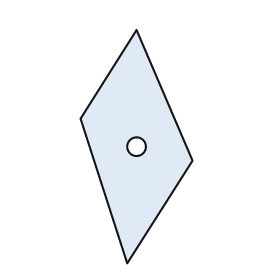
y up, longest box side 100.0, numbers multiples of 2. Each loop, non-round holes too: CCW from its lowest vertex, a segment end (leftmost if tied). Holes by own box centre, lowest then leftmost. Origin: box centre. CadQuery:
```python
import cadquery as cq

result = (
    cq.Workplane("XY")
    .moveTo(-4.0, -50.0)
    .lineTo(24.0, -6.0)
    .lineTo(0.0, 50.0)
    .lineTo(-24.0, 12.0)
    .close()
    .moveTo(0.0, 0.0)
    .circle(4.0)
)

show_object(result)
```